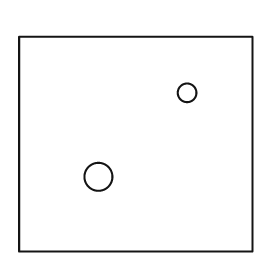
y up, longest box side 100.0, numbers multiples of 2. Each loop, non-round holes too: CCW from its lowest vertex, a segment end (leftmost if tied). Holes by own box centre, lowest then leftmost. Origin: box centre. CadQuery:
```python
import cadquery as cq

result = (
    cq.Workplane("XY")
    .moveTo(-50.0, -46.0)
    .lineTo(50.0, -46.0)
    .lineTo(50.0, 46.0)
    .lineTo(-50.0, 46.0)
    .close()
    .moveTo(-16.0, -14.0)
    .circle(6.0)
    .moveTo(22.0, 22.0)
    .circle(4.0)
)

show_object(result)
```